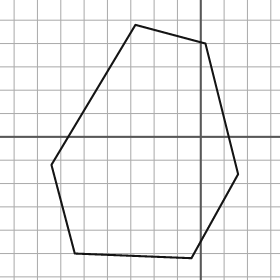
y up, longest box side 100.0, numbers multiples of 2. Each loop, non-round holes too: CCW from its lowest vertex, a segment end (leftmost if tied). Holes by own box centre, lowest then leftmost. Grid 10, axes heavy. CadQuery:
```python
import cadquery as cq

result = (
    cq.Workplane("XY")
    .moveTo(-4.0, -52.0)
    .lineTo(16.0, -16.0)
    .lineTo(2.0, 40.0)
    .lineTo(-28.0, 48.0)
    .lineTo(-64.0, -12.0)
    .lineTo(-54.0, -50.0)
    .close()
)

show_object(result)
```